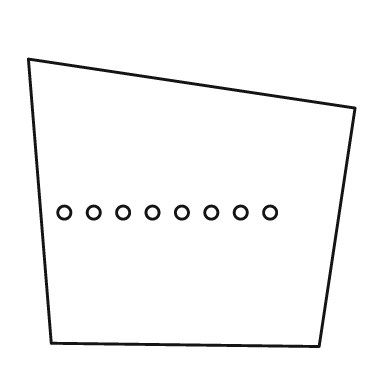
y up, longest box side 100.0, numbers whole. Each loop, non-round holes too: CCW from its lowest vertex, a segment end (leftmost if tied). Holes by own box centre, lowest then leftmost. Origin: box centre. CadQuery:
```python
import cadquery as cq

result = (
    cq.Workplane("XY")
    .moveTo(39.0, -44.0)
    .lineTo(50.0, 29.0)
    .lineTo(-50.0, 44.0)
    .lineTo(-43.0, -43.0)
    .close()
    .moveTo(-39.0, -3.0)
    .circle(2.0)
    .moveTo(-30.0, -3.0)
    .circle(2.0)
    .moveTo(-21.0, -3.0)
    .circle(2.0)
    .moveTo(-12.0, -3.0)
    .circle(2.0)
    .moveTo(-3.0, -3.0)
    .circle(2.0)
    .moveTo(6.0, -3.0)
    .circle(2.0)
    .moveTo(15.0, -3.0)
    .circle(2.0)
    .moveTo(24.0, -3.0)
    .circle(2.0)
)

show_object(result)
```